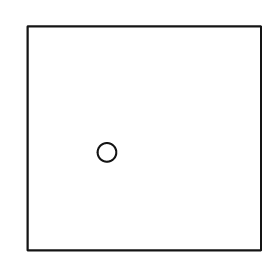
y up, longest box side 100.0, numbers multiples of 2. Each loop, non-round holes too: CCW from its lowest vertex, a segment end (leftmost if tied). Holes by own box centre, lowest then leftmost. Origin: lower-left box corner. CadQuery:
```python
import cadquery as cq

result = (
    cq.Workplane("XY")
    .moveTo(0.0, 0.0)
    .lineTo(100.0, 0.0)
    .lineTo(100.0, 96.0)
    .lineTo(0.0, 96.0)
    .close()
    .moveTo(34.0, 42.0)
    .circle(4.0)
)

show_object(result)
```